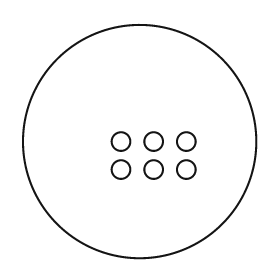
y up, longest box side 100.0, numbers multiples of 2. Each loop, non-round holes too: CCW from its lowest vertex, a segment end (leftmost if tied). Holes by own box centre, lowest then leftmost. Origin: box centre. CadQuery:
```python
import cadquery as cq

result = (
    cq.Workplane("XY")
    .moveTo(0.0, 0.0)
    .circle(50.0)
    .moveTo(-8.0, -12.0)
    .circle(4.0)
    .moveTo(6.0, -12.0)
    .circle(4.0)
    .moveTo(20.0, -12.0)
    .circle(4.0)
    .moveTo(-8.0, 0.0)
    .circle(4.0)
    .moveTo(6.0, 0.0)
    .circle(4.0)
    .moveTo(20.0, 0.0)
    .circle(4.0)
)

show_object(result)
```